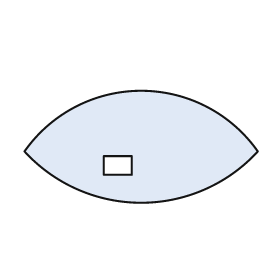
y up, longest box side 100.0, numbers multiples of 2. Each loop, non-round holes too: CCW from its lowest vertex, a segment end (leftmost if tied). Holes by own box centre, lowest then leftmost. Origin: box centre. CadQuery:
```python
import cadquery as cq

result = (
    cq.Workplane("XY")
    .moveTo(-50.0, -2.0)
    .threePointArc((0.0, -24.0), (50.0, -2.0))
    .threePointArc((0.0, 24.0), (-50.0, -2.0))
    .close()
    .moveTo(-16.0, -12.0)
    .lineTo(-4.0, -12.0)
    .lineTo(-4.0, -4.0)
    .lineTo(-16.0, -4.0)
    .close()
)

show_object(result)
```